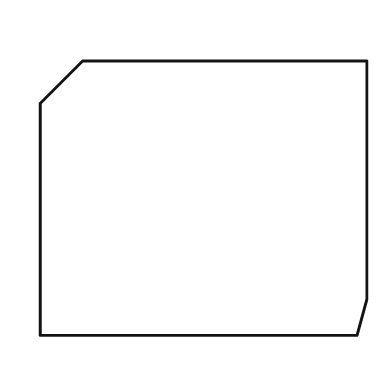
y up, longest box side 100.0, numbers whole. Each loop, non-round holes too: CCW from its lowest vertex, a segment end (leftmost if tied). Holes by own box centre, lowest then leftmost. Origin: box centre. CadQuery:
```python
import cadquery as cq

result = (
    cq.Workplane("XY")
    .moveTo(-50.0, -42.0)
    .lineTo(47.0, -42.0)
    .lineTo(50.0, -31.0)
    .lineTo(50.0, 42.0)
    .lineTo(-37.0, 42.0)
    .lineTo(-50.0, 29.0)
    .close()
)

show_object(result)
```